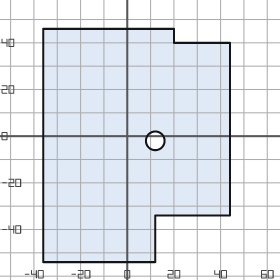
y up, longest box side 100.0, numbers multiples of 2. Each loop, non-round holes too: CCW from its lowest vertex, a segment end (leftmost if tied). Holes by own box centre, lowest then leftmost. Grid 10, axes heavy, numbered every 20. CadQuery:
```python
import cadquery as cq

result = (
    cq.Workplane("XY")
    .moveTo(-36.0, -54.0)
    .lineTo(12.0, -54.0)
    .lineTo(12.0, -34.0)
    .lineTo(44.0, -34.0)
    .lineTo(44.0, 40.0)
    .lineTo(20.0, 40.0)
    .lineTo(20.0, 46.0)
    .lineTo(-36.0, 46.0)
    .close()
    .moveTo(12.0, -2.0)
    .circle(4.0)
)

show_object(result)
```